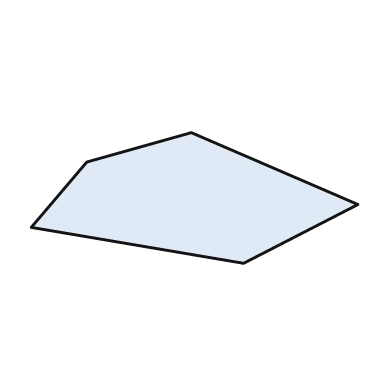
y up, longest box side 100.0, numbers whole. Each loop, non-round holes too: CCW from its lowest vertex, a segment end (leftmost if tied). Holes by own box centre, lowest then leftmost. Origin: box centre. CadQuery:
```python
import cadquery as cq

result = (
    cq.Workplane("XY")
    .moveTo(15.0, -20.0)
    .lineTo(50.0, -2.0)
    .lineTo(-1.0, 20.0)
    .lineTo(-33.0, 11.0)
    .lineTo(-50.0, -9.0)
    .close()
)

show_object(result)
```